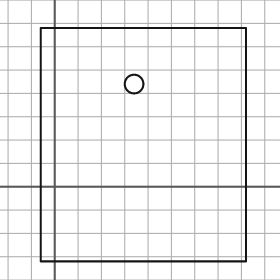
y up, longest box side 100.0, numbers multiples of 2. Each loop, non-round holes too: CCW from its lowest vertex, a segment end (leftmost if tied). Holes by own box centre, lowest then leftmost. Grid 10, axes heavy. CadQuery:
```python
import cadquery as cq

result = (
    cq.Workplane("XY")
    .moveTo(-6.0, -32.0)
    .lineTo(82.0, -32.0)
    .lineTo(82.0, 68.0)
    .lineTo(-6.0, 68.0)
    .close()
    .moveTo(34.0, 44.0)
    .circle(4.0)
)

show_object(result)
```